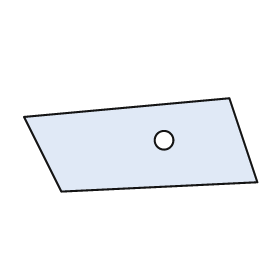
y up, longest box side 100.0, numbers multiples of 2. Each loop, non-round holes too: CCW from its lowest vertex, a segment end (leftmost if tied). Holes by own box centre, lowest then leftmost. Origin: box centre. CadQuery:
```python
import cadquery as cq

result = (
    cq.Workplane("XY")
    .moveTo(-34.0, -20.0)
    .lineTo(50.0, -16.0)
    .lineTo(38.0, 20.0)
    .lineTo(-50.0, 12.0)
    .close()
    .moveTo(10.0, 2.0)
    .circle(4.0)
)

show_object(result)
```